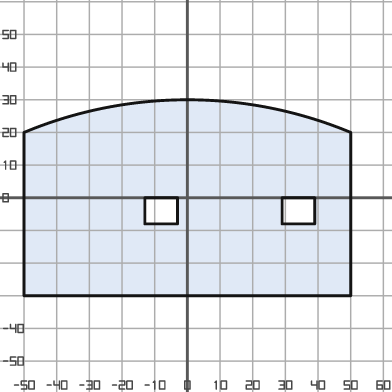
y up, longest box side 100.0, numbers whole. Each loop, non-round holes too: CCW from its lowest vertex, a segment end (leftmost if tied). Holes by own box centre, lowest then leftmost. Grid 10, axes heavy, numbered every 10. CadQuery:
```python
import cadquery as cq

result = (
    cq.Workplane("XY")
    .moveTo(-50.0, -30.0)
    .lineTo(50.0, -30.0)
    .lineTo(50.0, 20.0)
    .threePointArc((0.0, 30.0), (-50.0, 20.0))
    .close()
    .moveTo(-13.0, -8.0)
    .lineTo(-3.0, -8.0)
    .lineTo(-3.0, 0.0)
    .lineTo(-13.0, 0.0)
    .close()
    .moveTo(29.0, -8.0)
    .lineTo(39.0, -8.0)
    .lineTo(39.0, 0.0)
    .lineTo(29.0, 0.0)
    .close()
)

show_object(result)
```